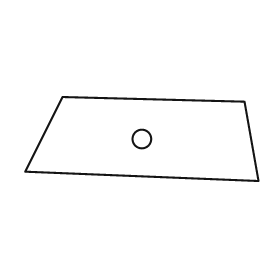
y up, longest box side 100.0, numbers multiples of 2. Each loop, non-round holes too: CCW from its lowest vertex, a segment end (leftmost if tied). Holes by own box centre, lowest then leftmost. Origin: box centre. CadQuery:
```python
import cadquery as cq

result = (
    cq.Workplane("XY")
    .moveTo(50.0, -18.0)
    .lineTo(44.0, 16.0)
    .lineTo(-34.0, 18.0)
    .lineTo(-50.0, -14.0)
    .close()
    .moveTo(0.0, 0.0)
    .circle(4.0)
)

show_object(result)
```